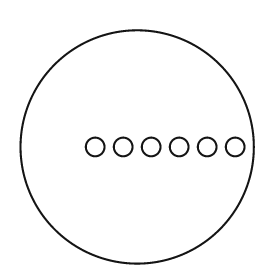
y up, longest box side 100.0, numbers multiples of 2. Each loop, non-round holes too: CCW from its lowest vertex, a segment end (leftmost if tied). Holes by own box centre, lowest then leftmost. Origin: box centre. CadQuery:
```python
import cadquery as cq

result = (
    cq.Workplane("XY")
    .moveTo(0.0, 0.0)
    .circle(50.0)
    .moveTo(-18.0, 0.0)
    .circle(4.0)
    .moveTo(-6.0, 0.0)
    .circle(4.0)
    .moveTo(6.0, 0.0)
    .circle(4.0)
    .moveTo(18.0, 0.0)
    .circle(4.0)
    .moveTo(30.0, 0.0)
    .circle(4.0)
    .moveTo(42.0, 0.0)
    .circle(4.0)
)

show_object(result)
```